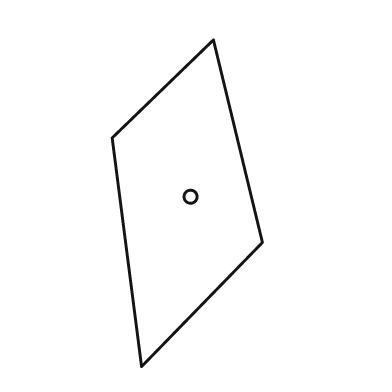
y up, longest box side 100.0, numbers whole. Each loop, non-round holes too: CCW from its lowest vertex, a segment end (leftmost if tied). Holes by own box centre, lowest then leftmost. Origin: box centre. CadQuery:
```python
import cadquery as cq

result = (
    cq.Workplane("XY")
    .moveTo(-14.0, -50.0)
    .lineTo(23.0, -12.0)
    .lineTo(8.0, 50.0)
    .lineTo(-23.0, 20.0)
    .close()
    .moveTo(1.0, 2.0)
    .circle(2.0)
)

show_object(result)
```